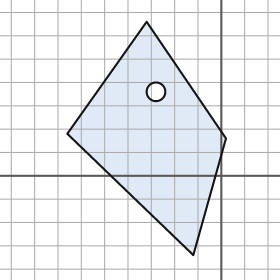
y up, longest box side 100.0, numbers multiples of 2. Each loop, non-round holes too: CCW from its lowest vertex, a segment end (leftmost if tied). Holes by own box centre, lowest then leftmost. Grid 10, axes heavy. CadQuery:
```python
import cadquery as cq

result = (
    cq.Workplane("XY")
    .moveTo(-12.0, -34.0)
    .lineTo(2.0, 16.0)
    .lineTo(-32.0, 66.0)
    .lineTo(-66.0, 18.0)
    .close()
    .moveTo(-28.0, 36.0)
    .circle(4.0)
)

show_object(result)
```